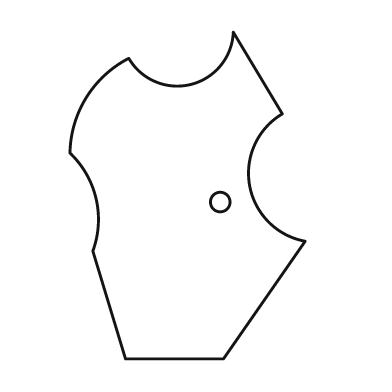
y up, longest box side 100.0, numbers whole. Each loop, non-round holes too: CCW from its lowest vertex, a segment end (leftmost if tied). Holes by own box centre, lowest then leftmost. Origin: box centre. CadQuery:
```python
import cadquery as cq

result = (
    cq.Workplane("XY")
    .moveTo(-19.0, -50.0)
    .lineTo(11.0, -50.0)
    .lineTo(36.0, -14.0)
    .threePointArc((19.0, 3.0), (29.0, 25.0))
    .lineTo(14.0, 50.0)
    .threePointArc((1.0, 34.0), (-18.0, 42.0))
    .threePointArc((-31.0, 30.0), (-36.0, 13.0))
    .threePointArc((-28.0, -1.0), (-29.0, -17.0))
    .close()
    .moveTo(10.0, -2.0)
    .circle(3.0)
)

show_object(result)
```